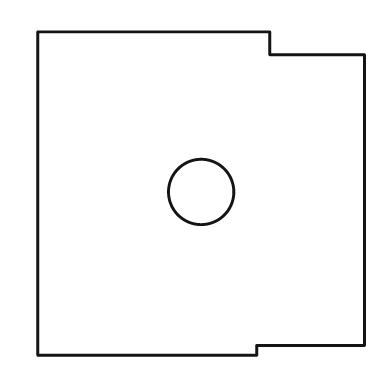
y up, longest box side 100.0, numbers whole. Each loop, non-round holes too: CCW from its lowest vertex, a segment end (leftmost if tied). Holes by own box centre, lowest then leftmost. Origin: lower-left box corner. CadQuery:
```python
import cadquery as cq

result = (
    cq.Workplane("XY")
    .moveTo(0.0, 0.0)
    .lineTo(67.0, 0.0)
    .lineTo(67.0, 3.0)
    .lineTo(100.0, 3.0)
    .lineTo(100.0, 92.0)
    .lineTo(71.0, 92.0)
    .lineTo(71.0, 99.0)
    .lineTo(0.0, 99.0)
    .close()
    .moveTo(50.0, 50.0)
    .circle(10.0)
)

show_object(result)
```